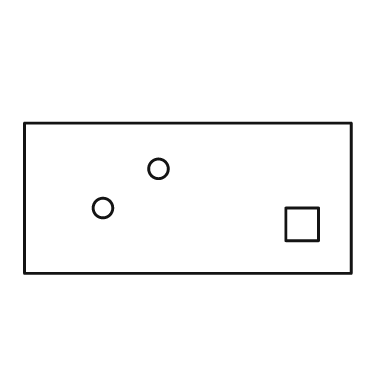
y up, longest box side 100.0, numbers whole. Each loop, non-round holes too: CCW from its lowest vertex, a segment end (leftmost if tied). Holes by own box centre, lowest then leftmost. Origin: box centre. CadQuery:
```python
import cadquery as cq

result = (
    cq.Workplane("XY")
    .moveTo(-50.0, -23.0)
    .lineTo(50.0, -23.0)
    .lineTo(50.0, 23.0)
    .lineTo(-50.0, 23.0)
    .close()
    .moveTo(30.0, -13.0)
    .lineTo(40.0, -13.0)
    .lineTo(40.0, -3.0)
    .lineTo(30.0, -3.0)
    .close()
    .moveTo(-26.0, -3.0)
    .circle(3.0)
    .moveTo(-9.0, 9.0)
    .circle(3.0)
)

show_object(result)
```